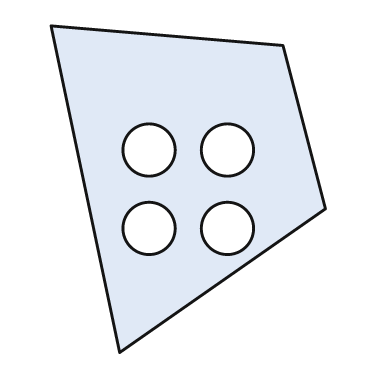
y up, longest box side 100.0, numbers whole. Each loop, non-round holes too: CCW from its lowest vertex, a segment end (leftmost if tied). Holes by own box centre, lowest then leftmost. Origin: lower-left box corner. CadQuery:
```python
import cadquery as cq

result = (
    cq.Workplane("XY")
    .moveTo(21.0, 0.0)
    .lineTo(84.0, 44.0)
    .lineTo(71.0, 94.0)
    .lineTo(0.0, 100.0)
    .close()
    .moveTo(30.0, 38.0)
    .circle(8.0)
    .moveTo(54.0, 38.0)
    .circle(8.0)
    .moveTo(30.0, 62.0)
    .circle(8.0)
    .moveTo(54.0, 62.0)
    .circle(8.0)
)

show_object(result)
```